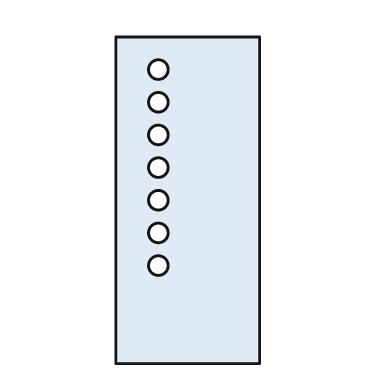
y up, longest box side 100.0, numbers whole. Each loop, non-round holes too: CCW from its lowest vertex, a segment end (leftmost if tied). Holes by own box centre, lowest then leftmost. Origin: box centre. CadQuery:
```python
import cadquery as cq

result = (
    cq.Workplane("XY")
    .moveTo(-22.0, -50.0)
    .lineTo(22.0, -50.0)
    .lineTo(22.0, 50.0)
    .lineTo(-22.0, 50.0)
    .close()
    .moveTo(-9.0, -20.0)
    .circle(3.0)
    .moveTo(-9.0, -10.0)
    .circle(3.0)
    .moveTo(-9.0, 0.0)
    .circle(3.0)
    .moveTo(-9.0, 10.0)
    .circle(3.0)
    .moveTo(-9.0, 20.0)
    .circle(3.0)
    .moveTo(-9.0, 30.0)
    .circle(3.0)
    .moveTo(-9.0, 40.0)
    .circle(3.0)
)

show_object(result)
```